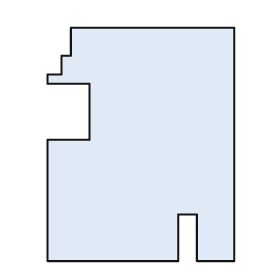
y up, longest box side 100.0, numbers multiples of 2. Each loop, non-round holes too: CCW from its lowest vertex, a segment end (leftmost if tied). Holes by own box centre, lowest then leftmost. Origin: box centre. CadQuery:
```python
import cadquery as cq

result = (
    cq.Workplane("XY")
    .moveTo(-40.0, -50.0)
    .lineTo(16.0, -50.0)
    .lineTo(16.0, -30.0)
    .lineTo(24.0, -30.0)
    .lineTo(24.0, -50.0)
    .lineTo(40.0, -50.0)
    .lineTo(40.0, 50.0)
    .lineTo(-30.0, 50.0)
    .lineTo(-30.0, 38.0)
    .lineTo(-34.0, 38.0)
    .lineTo(-34.0, 30.0)
    .lineTo(-40.0, 30.0)
    .lineTo(-40.0, 26.0)
    .lineTo(-22.0, 26.0)
    .lineTo(-22.0, 2.0)
    .lineTo(-40.0, 2.0)
    .close()
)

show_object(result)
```